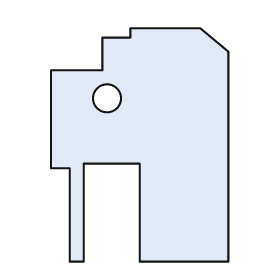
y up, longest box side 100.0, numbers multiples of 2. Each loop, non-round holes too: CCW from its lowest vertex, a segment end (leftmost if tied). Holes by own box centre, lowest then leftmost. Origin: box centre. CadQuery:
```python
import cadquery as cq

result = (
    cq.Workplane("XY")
    .moveTo(-30.0, -50.0)
    .lineTo(-24.0, -50.0)
    .lineTo(-24.0, -8.0)
    .lineTo(0.0, -8.0)
    .lineTo(0.0, -50.0)
    .lineTo(38.0, -50.0)
    .lineTo(38.0, 40.0)
    .lineTo(26.0, 50.0)
    .lineTo(-4.0, 50.0)
    .lineTo(-4.0, 46.0)
    .lineTo(-16.0, 46.0)
    .lineTo(-16.0, 32.0)
    .lineTo(-38.0, 32.0)
    .lineTo(-38.0, -10.0)
    .lineTo(-30.0, -10.0)
    .close()
    .moveTo(-14.0, 20.0)
    .circle(6.0)
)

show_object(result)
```